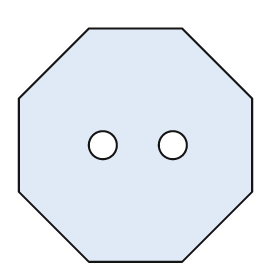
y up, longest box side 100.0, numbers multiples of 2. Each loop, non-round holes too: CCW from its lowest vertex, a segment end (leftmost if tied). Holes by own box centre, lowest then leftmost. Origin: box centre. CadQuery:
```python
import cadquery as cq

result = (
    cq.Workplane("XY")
    .moveTo(-20.0, -50.0)
    .lineTo(20.0, -50.0)
    .lineTo(50.0, -20.0)
    .lineTo(50.0, 20.0)
    .lineTo(20.0, 50.0)
    .lineTo(-20.0, 50.0)
    .lineTo(-50.0, 20.0)
    .lineTo(-50.0, -20.0)
    .close()
    .moveTo(-14.0, 0.0)
    .circle(6.0)
    .moveTo(16.0, 0.0)
    .circle(6.0)
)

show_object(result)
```